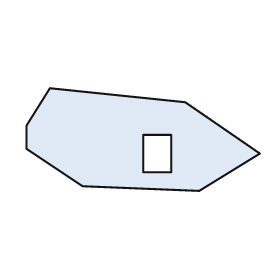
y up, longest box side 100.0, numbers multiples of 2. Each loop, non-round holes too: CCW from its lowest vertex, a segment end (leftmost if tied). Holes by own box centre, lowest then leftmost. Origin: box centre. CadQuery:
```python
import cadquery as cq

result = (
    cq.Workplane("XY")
    .moveTo(24.0, -22.0)
    .lineTo(50.0, -6.0)
    .lineTo(18.0, 16.0)
    .lineTo(-40.0, 22.0)
    .lineTo(-50.0, 6.0)
    .lineTo(-50.0, -4.0)
    .lineTo(-26.0, -20.0)
    .close()
    .moveTo(0.0, -14.0)
    .lineTo(12.0, -14.0)
    .lineTo(12.0, 2.0)
    .lineTo(0.0, 2.0)
    .close()
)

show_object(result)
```